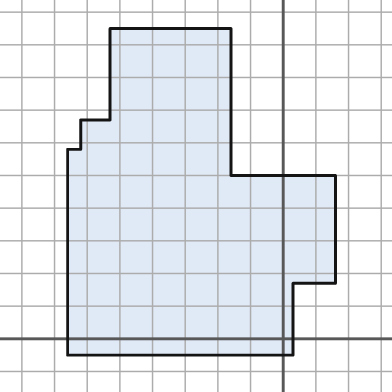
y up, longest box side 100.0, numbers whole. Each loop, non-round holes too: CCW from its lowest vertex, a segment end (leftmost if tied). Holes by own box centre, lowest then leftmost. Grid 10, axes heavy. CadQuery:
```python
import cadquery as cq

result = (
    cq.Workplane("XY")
    .moveTo(-66.0, -5.0)
    .lineTo(3.0, -5.0)
    .lineTo(3.0, 17.0)
    .lineTo(16.0, 17.0)
    .lineTo(16.0, 50.0)
    .lineTo(-16.0, 50.0)
    .lineTo(-16.0, 95.0)
    .lineTo(-53.0, 95.0)
    .lineTo(-53.0, 67.0)
    .lineTo(-62.0, 67.0)
    .lineTo(-62.0, 58.0)
    .lineTo(-66.0, 58.0)
    .close()
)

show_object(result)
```